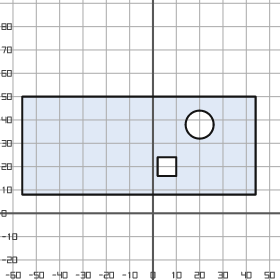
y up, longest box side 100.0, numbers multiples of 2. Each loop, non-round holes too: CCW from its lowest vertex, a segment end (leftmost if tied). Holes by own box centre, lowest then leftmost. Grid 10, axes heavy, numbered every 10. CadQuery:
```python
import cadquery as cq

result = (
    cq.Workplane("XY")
    .moveTo(-56.0, 8.0)
    .lineTo(44.0, 8.0)
    .lineTo(44.0, 50.0)
    .lineTo(-56.0, 50.0)
    .close()
    .moveTo(2.0, 16.0)
    .lineTo(10.0, 16.0)
    .lineTo(10.0, 24.0)
    .lineTo(2.0, 24.0)
    .close()
    .moveTo(20.0, 38.0)
    .circle(6.0)
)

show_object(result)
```